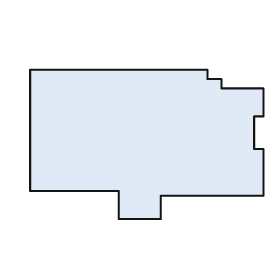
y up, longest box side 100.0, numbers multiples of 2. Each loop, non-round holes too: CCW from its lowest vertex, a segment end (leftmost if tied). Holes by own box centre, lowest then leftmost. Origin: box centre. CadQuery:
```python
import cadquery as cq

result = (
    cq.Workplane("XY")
    .moveTo(-12.0, -32.0)
    .lineTo(6.0, -32.0)
    .lineTo(6.0, -22.0)
    .lineTo(50.0, -22.0)
    .lineTo(50.0, -2.0)
    .lineTo(46.0, -2.0)
    .lineTo(46.0, 12.0)
    .lineTo(50.0, 12.0)
    .lineTo(50.0, 24.0)
    .lineTo(32.0, 24.0)
    .lineTo(32.0, 28.0)
    .lineTo(26.0, 28.0)
    .lineTo(26.0, 32.0)
    .lineTo(-50.0, 32.0)
    .lineTo(-50.0, -20.0)
    .lineTo(-12.0, -20.0)
    .close()
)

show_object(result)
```